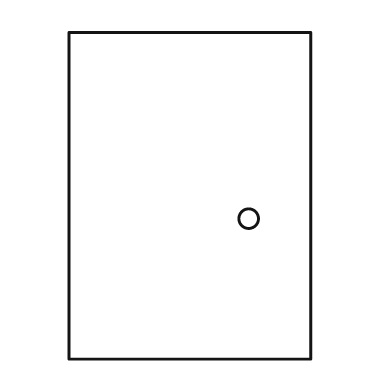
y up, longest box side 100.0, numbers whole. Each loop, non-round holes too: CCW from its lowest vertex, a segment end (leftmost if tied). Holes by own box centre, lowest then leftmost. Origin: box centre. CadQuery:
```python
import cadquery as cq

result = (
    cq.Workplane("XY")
    .moveTo(-37.0, -50.0)
    .lineTo(37.0, -50.0)
    .lineTo(37.0, 50.0)
    .lineTo(-37.0, 50.0)
    .close()
    .moveTo(18.0, -7.0)
    .circle(3.0)
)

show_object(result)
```